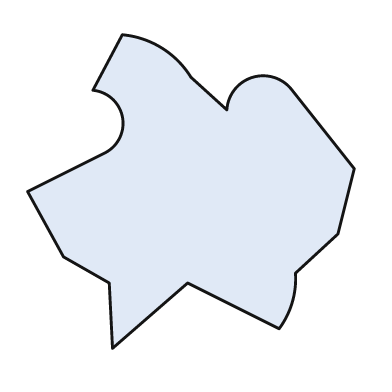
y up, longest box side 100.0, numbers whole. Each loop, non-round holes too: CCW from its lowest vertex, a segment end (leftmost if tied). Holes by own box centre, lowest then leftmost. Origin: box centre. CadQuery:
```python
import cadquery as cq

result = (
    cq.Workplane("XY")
    .moveTo(-24.0, -48.0)
    .lineTo(-1.0, -28.0)
    .lineTo(27.0, -42.0)
    .threePointArc((31.0, -34.0), (32.0, -25.0))
    .lineTo(45.0, -13.0)
    .lineTo(50.0, 7.0)
    .lineTo(31.0, 31.0)
    .threePointArc((19.0, 35.0), (11.0, 25.0))
    .lineTo(0.0, 35.0)
    .threePointArc((-9.0, 44.0), (-21.0, 48.0))
    .lineTo(-30.0, 31.0)
    .threePointArc((-21.0, 23.0), (-26.0, 12.0))
    .lineTo(-50.0, 0.0)
    .lineTo(-39.0, -20.0)
    .lineTo(-25.0, -28.0)
    .close()
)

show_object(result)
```